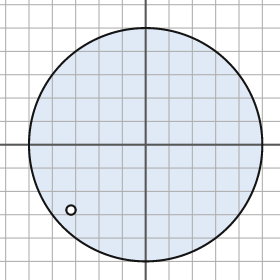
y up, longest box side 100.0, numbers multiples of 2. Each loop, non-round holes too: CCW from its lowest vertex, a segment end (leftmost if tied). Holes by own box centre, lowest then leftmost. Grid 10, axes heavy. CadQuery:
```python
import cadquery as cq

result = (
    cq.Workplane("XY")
    .moveTo(0.0, 0.0)
    .circle(50.0)
    .moveTo(-32.0, -28.0)
    .circle(2.0)
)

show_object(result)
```